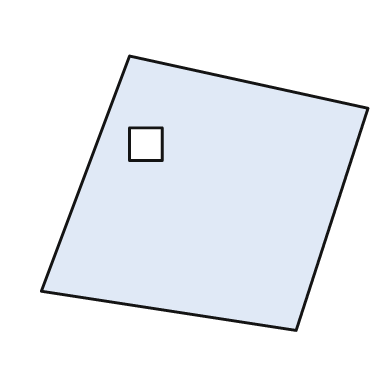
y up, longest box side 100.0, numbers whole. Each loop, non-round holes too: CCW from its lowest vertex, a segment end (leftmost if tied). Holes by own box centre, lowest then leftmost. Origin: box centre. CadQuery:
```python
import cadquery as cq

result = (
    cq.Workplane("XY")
    .moveTo(28.0, -42.0)
    .lineTo(50.0, 26.0)
    .lineTo(-23.0, 42.0)
    .lineTo(-50.0, -30.0)
    .close()
    .moveTo(-23.0, 10.0)
    .lineTo(-13.0, 10.0)
    .lineTo(-13.0, 20.0)
    .lineTo(-23.0, 20.0)
    .close()
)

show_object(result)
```